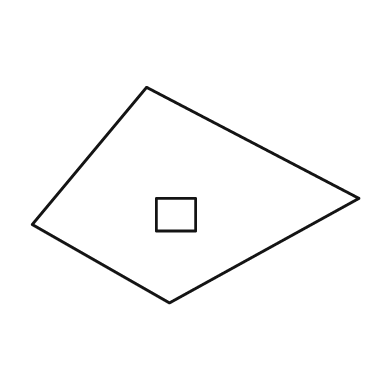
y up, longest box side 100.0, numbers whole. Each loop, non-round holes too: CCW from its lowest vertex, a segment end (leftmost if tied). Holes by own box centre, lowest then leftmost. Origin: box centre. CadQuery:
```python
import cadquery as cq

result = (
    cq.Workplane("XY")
    .moveTo(-8.0, -33.0)
    .lineTo(50.0, -1.0)
    .lineTo(-15.0, 33.0)
    .lineTo(-50.0, -9.0)
    .close()
    .moveTo(-12.0, -11.0)
    .lineTo(0.0, -11.0)
    .lineTo(0.0, -1.0)
    .lineTo(-12.0, -1.0)
    .close()
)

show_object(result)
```